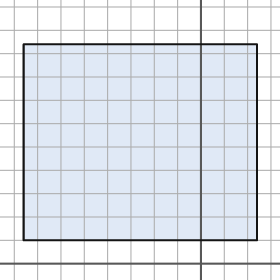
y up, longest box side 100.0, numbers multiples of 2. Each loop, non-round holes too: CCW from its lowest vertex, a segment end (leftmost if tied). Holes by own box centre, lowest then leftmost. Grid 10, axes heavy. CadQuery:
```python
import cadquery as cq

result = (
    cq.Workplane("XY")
    .moveTo(-76.0, 10.0)
    .lineTo(24.0, 10.0)
    .lineTo(24.0, 94.0)
    .lineTo(-76.0, 94.0)
    .close()
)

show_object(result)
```